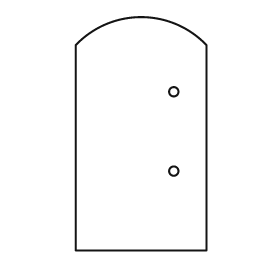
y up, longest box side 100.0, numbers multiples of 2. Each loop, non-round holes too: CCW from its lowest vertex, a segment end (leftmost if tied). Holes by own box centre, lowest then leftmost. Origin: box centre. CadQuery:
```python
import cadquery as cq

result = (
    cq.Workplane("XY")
    .moveTo(-28.0, -50.0)
    .lineTo(28.0, -50.0)
    .lineTo(28.0, 38.0)
    .threePointArc((0.0, 50.0), (-28.0, 38.0))
    .close()
    .moveTo(14.0, -16.0)
    .circle(2.0)
    .moveTo(14.0, 18.0)
    .circle(2.0)
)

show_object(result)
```